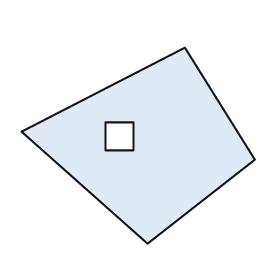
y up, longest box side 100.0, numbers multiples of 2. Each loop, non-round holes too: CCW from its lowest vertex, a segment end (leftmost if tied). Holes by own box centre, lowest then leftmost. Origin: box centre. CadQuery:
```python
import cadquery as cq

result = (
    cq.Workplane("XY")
    .moveTo(4.0, -42.0)
    .lineTo(50.0, -6.0)
    .lineTo(20.0, 42.0)
    .lineTo(-50.0, 6.0)
    .close()
    .moveTo(-14.0, -2.0)
    .lineTo(-2.0, -2.0)
    .lineTo(-2.0, 10.0)
    .lineTo(-14.0, 10.0)
    .close()
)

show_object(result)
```